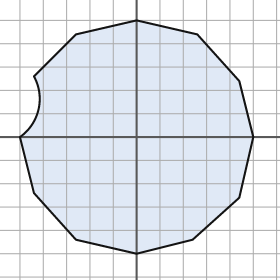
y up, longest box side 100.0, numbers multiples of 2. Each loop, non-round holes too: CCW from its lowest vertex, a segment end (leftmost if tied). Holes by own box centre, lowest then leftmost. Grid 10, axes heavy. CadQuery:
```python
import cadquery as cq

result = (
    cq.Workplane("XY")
    .moveTo(0.0, -50.0)
    .lineTo(24.0, -44.0)
    .lineTo(44.0, -26.0)
    .lineTo(50.0, 0.0)
    .lineTo(44.0, 24.0)
    .lineTo(26.0, 44.0)
    .lineTo(0.0, 50.0)
    .lineTo(-26.0, 44.0)
    .lineTo(-44.0, 26.0)
    .threePointArc((-42.0, 12.0), (-50.0, 0.0))
    .lineTo(-44.0, -24.0)
    .lineTo(-26.0, -44.0)
    .close()
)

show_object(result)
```